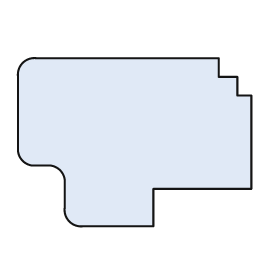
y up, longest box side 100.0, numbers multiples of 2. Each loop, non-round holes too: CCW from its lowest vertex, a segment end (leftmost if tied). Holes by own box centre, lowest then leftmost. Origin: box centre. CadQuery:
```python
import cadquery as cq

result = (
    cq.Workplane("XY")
    .moveTo(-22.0, -36.0)
    .lineTo(8.0, -36.0)
    .lineTo(8.0, -20.0)
    .lineTo(50.0, -20.0)
    .lineTo(50.0, 20.0)
    .lineTo(44.0, 20.0)
    .lineTo(44.0, 28.0)
    .lineTo(36.0, 28.0)
    .lineTo(36.0, 36.0)
    .lineTo(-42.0, 36.0)
    .threePointArc((-48.0, 34.0), (-50.0, 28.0))
    .lineTo(-50.0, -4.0)
    .threePointArc((-48.0, -8.0), (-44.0, -10.0))
    .lineTo(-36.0, -10.0)
    .threePointArc((-32.0, -12.0), (-30.0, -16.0))
    .lineTo(-30.0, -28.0)
    .threePointArc((-28.0, -34.0), (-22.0, -36.0))
    .close()
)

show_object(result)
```